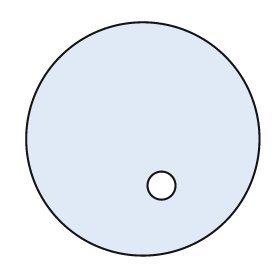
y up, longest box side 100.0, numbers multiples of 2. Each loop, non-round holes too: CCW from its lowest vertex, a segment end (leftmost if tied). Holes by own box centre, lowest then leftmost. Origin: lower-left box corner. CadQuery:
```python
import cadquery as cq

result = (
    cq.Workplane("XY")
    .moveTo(50.0, 50.0)
    .circle(50.0)
    .moveTo(58.0, 30.0)
    .circle(6.0)
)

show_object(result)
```